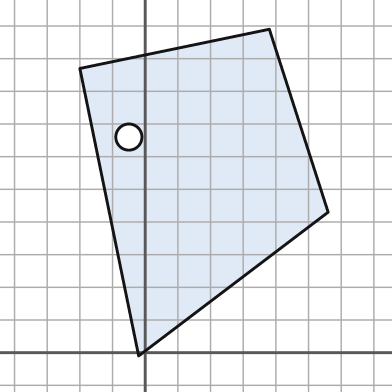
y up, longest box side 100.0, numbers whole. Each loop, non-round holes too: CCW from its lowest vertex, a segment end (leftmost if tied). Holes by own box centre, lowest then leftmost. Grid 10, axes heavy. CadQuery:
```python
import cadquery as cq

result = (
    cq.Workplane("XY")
    .moveTo(-2.0, -1.0)
    .lineTo(56.0, 43.0)
    .lineTo(38.0, 99.0)
    .lineTo(-20.0, 87.0)
    .close()
    .moveTo(-5.0, 66.0)
    .circle(4.0)
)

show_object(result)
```